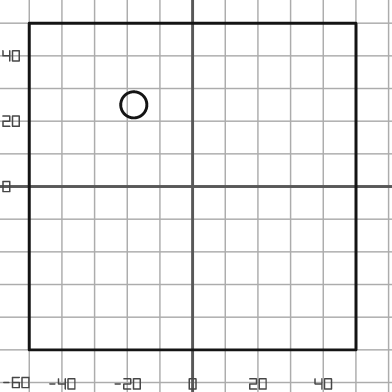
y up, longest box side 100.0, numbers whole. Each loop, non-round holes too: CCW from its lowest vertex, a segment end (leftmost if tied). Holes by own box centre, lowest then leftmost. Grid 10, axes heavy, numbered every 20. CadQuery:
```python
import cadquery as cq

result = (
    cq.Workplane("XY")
    .moveTo(-50.0, -50.0)
    .lineTo(50.0, -50.0)
    .lineTo(50.0, 50.0)
    .lineTo(-50.0, 50.0)
    .close()
    .moveTo(-18.0, 25.0)
    .circle(4.0)
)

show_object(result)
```